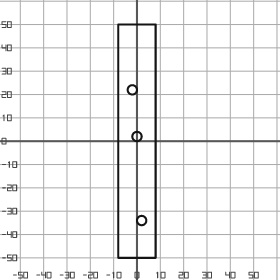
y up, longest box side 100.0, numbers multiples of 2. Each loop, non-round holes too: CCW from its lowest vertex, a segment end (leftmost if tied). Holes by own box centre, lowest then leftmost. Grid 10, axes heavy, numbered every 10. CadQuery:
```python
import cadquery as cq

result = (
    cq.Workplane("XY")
    .moveTo(-8.0, -50.0)
    .lineTo(8.0, -50.0)
    .lineTo(8.0, 50.0)
    .lineTo(-8.0, 50.0)
    .close()
    .moveTo(2.0, -34.0)
    .circle(2.0)
    .moveTo(0.0, 2.0)
    .circle(2.0)
    .moveTo(-2.0, 22.0)
    .circle(2.0)
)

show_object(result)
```